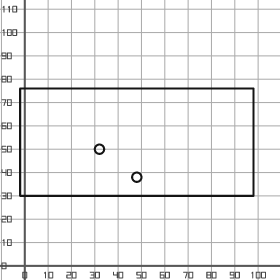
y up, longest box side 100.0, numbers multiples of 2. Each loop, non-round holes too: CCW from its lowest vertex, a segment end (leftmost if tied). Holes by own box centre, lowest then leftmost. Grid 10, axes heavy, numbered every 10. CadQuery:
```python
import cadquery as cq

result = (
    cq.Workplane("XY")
    .moveTo(-2.0, 30.0)
    .lineTo(98.0, 30.0)
    .lineTo(98.0, 76.0)
    .lineTo(-2.0, 76.0)
    .close()
    .moveTo(48.0, 38.0)
    .circle(2.0)
    .moveTo(32.0, 50.0)
    .circle(2.0)
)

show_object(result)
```